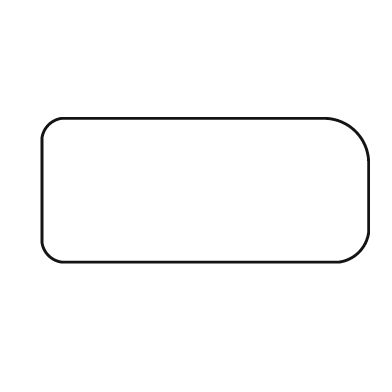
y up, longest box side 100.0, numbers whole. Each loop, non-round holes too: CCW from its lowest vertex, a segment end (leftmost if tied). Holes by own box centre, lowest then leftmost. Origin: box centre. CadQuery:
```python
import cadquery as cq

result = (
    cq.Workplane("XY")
    .moveTo(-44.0, -22.0)
    .lineTo(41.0, -22.0)
    .threePointArc((47.0, -19.0), (50.0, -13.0))
    .lineTo(50.0, 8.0)
    .threePointArc((46.0, 18.0), (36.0, 22.0))
    .lineTo(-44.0, 22.0)
    .threePointArc((-48.0, 20.0), (-50.0, 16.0))
    .lineTo(-50.0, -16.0)
    .threePointArc((-48.0, -20.0), (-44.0, -22.0))
    .close()
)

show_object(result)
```